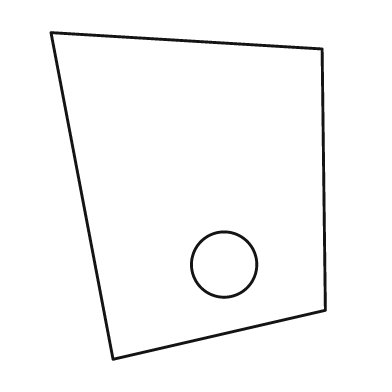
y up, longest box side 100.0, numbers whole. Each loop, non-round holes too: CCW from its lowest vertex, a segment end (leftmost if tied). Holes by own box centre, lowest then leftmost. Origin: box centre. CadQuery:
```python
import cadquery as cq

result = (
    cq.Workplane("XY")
    .moveTo(-23.0, -50.0)
    .lineTo(42.0, -35.0)
    .lineTo(41.0, 45.0)
    .lineTo(-42.0, 50.0)
    .close()
    .moveTo(11.0, -21.0)
    .circle(10.0)
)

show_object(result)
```